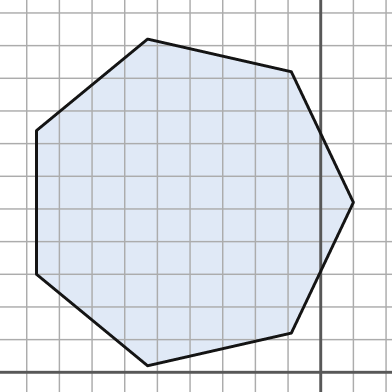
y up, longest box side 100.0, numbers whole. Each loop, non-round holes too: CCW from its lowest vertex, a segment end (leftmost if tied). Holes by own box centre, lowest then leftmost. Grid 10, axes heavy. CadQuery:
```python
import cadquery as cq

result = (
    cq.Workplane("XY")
    .moveTo(-53.0, 2.0)
    .lineTo(-9.0, 12.0)
    .lineTo(10.0, 52.0)
    .lineTo(-9.0, 92.0)
    .lineTo(-53.0, 102.0)
    .lineTo(-87.0, 74.0)
    .lineTo(-87.0, 30.0)
    .close()
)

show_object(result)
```